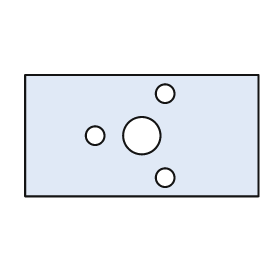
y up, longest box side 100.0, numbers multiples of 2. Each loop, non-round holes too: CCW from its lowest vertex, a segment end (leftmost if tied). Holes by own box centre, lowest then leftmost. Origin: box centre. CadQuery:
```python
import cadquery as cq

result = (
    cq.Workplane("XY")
    .moveTo(-50.0, -26.0)
    .lineTo(50.0, -26.0)
    .lineTo(50.0, 26.0)
    .lineTo(-50.0, 26.0)
    .close()
    .moveTo(10.0, -18.0)
    .circle(4.0)
    .moveTo(-20.0, 0.0)
    .circle(4.0)
    .moveTo(0.0, 0.0)
    .circle(8.0)
    .moveTo(10.0, 18.0)
    .circle(4.0)
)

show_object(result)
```